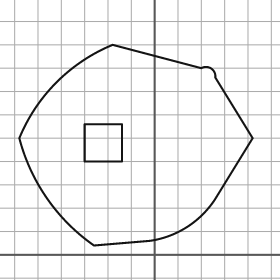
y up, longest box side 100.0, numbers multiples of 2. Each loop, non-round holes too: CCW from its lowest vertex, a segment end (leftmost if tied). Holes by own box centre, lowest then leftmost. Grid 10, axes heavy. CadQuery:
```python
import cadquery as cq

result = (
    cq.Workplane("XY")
    .moveTo(-26.0, 4.0)
    .lineTo(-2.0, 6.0)
    .threePointArc((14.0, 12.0), (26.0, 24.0))
    .lineTo(42.0, 50.0)
    .lineTo(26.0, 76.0)
    .threePointArc((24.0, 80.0), (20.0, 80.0))
    .lineTo(-18.0, 90.0)
    .threePointArc((-42.0, 74.0), (-58.0, 50.0))
    .threePointArc((-46.0, 24.0), (-26.0, 4.0))
    .close()
    .moveTo(-30.0, 40.0)
    .lineTo(-14.0, 40.0)
    .lineTo(-14.0, 56.0)
    .lineTo(-30.0, 56.0)
    .close()
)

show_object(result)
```